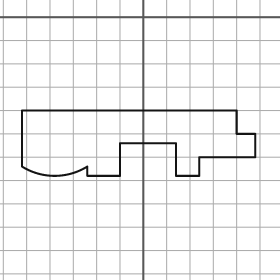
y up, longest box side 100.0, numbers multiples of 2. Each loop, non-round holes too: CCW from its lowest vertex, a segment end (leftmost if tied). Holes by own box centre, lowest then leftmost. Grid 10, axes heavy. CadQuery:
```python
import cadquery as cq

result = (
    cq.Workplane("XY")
    .moveTo(-24.0, -68.0)
    .lineTo(-10.0, -68.0)
    .lineTo(-10.0, -54.0)
    .lineTo(14.0, -54.0)
    .lineTo(14.0, -68.0)
    .lineTo(24.0, -68.0)
    .lineTo(24.0, -60.0)
    .lineTo(48.0, -60.0)
    .lineTo(48.0, -50.0)
    .lineTo(40.0, -50.0)
    .lineTo(40.0, -40.0)
    .lineTo(-52.0, -40.0)
    .lineTo(-52.0, -64.0)
    .threePointArc((-38.0, -68.0), (-24.0, -64.0))
    .close()
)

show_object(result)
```